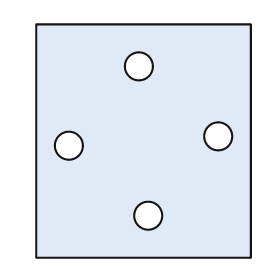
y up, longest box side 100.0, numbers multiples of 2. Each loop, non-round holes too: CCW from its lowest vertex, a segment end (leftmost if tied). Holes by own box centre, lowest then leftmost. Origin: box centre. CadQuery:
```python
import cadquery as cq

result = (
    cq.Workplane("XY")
    .moveTo(-46.0, -50.0)
    .lineTo(46.0, -50.0)
    .lineTo(46.0, 50.0)
    .lineTo(-46.0, 50.0)
    .close()
    .moveTo(2.0, -32.0)
    .circle(6.0)
    .moveTo(-32.0, -2.0)
    .circle(6.0)
    .moveTo(32.0, 2.0)
    .circle(6.0)
    .moveTo(-2.0, 32.0)
    .circle(6.0)
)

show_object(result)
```